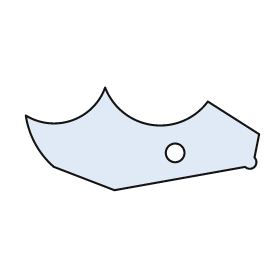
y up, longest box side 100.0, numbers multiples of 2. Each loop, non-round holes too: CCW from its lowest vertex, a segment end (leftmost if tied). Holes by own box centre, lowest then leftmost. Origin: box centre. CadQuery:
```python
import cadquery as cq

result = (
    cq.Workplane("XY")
    .moveTo(-12.0, -22.0)
    .lineTo(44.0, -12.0)
    .threePointArc((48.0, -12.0), (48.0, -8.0))
    .lineTo(50.0, 2.0)
    .lineTo(28.0, 16.0)
    .threePointArc((4.0, 6.0), (-16.0, 22.0))
    .threePointArc((-30.0, 8.0), (-50.0, 10.0))
    .threePointArc((-46.0, -2.0), (-38.0, -12.0))
    .close()
    .moveTo(14.0, -6.0)
    .circle(4.0)
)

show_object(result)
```